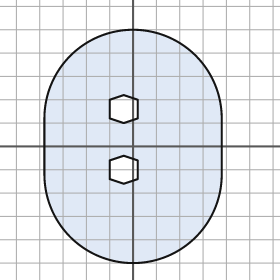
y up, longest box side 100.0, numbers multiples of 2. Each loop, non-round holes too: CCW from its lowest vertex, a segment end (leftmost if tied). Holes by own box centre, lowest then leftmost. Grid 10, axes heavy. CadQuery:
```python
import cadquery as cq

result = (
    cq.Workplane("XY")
    .moveTo(-38.0, -12.0)
    .threePointArc((0.0, -50.0), (38.0, -12.0))
    .lineTo(38.0, 12.0)
    .threePointArc((0.0, 50.0), (-38.0, 12.0))
    .close()
    .moveTo(-4.0, -16.0)
    .lineTo(2.0, -14.0)
    .lineTo(2.0, -6.0)
    .lineTo(-4.0, -4.0)
    .lineTo(-10.0, -6.0)
    .lineTo(-10.0, -14.0)
    .close()
    .moveTo(-4.0, 10.0)
    .lineTo(2.0, 12.0)
    .lineTo(2.0, 20.0)
    .lineTo(-4.0, 22.0)
    .lineTo(-10.0, 20.0)
    .lineTo(-10.0, 12.0)
    .close()
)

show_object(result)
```